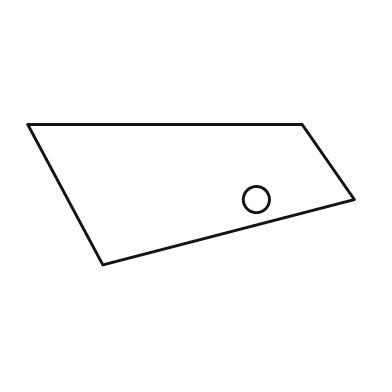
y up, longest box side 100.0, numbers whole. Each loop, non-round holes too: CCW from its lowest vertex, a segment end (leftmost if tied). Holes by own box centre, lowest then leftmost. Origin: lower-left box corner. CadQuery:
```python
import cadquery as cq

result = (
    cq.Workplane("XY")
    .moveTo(23.0, 0.0)
    .lineTo(100.0, 20.0)
    .lineTo(84.0, 43.0)
    .lineTo(0.0, 43.0)
    .close()
    .moveTo(70.0, 20.0)
    .circle(4.0)
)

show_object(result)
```